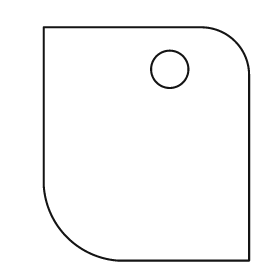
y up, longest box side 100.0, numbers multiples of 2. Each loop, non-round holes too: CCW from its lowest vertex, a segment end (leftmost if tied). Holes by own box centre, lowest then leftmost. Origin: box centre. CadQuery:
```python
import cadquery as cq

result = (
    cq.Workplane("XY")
    .moveTo(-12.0, -50.0)
    .lineTo(44.0, -50.0)
    .lineTo(44.0, 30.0)
    .threePointArc((38.0, 44.0), (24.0, 50.0))
    .lineTo(-44.0, 50.0)
    .lineTo(-44.0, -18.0)
    .threePointArc((-34.0, -40.0), (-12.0, -50.0))
    .close()
    .moveTo(10.0, 32.0)
    .circle(8.0)
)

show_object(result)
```